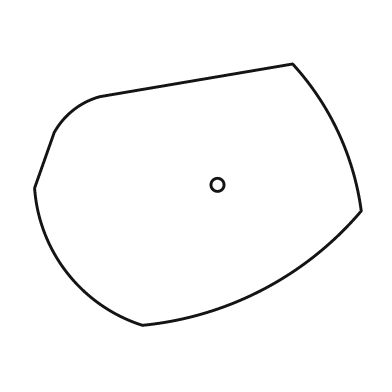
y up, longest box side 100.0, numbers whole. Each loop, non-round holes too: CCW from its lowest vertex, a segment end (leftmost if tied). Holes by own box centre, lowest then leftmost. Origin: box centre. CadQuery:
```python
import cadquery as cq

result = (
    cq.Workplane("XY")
    .moveTo(-17.0, -40.0)
    .threePointArc((20.0, -29.0), (50.0, -5.0))
    .threePointArc((43.0, 19.0), (29.0, 40.0))
    .lineTo(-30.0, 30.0)
    .threePointArc((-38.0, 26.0), (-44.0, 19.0))
    .lineTo(-50.0, 2.0)
    .threePointArc((-40.0, -24.0), (-17.0, -40.0))
    .close()
    .moveTo(6.0, 3.0)
    .circle(2.0)
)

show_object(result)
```